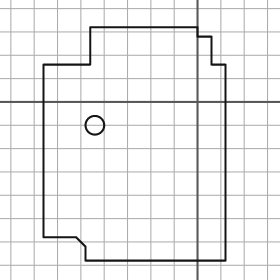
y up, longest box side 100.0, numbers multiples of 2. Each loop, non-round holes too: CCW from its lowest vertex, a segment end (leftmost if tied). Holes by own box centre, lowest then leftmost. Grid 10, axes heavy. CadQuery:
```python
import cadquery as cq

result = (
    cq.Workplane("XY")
    .moveTo(-48.0, -68.0)
    .lineTo(12.0, -68.0)
    .lineTo(12.0, 16.0)
    .lineTo(6.0, 16.0)
    .lineTo(6.0, 28.0)
    .lineTo(0.0, 28.0)
    .lineTo(0.0, 32.0)
    .lineTo(-46.0, 32.0)
    .lineTo(-46.0, 16.0)
    .lineTo(-66.0, 16.0)
    .lineTo(-66.0, -58.0)
    .lineTo(-52.0, -58.0)
    .lineTo(-48.0, -62.0)
    .close()
    .moveTo(-44.0, -10.0)
    .circle(4.0)
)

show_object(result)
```